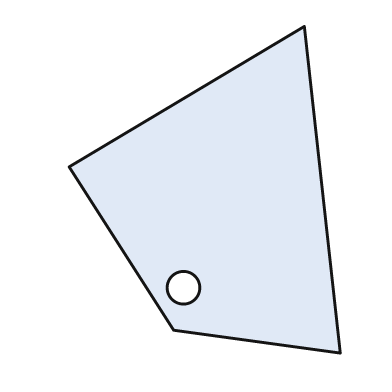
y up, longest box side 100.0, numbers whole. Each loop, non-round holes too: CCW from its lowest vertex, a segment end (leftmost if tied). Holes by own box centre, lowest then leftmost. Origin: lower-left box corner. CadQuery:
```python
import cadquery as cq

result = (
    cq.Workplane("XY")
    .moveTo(83.0, 0.0)
    .lineTo(72.0, 100.0)
    .lineTo(0.0, 57.0)
    .lineTo(32.0, 7.0)
    .close()
    .moveTo(35.0, 20.0)
    .circle(5.0)
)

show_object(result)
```